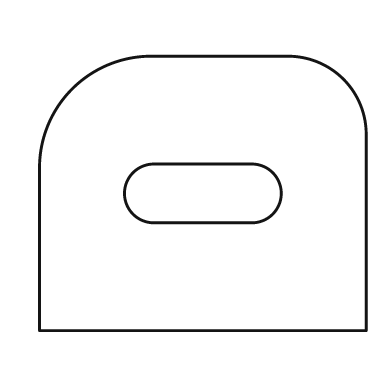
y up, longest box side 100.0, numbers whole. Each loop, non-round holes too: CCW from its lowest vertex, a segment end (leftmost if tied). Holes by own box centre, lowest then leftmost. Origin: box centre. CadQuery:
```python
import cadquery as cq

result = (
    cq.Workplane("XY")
    .moveTo(-50.0, -42.0)
    .lineTo(50.0, -42.0)
    .lineTo(50.0, 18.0)
    .threePointArc((43.0, 35.0), (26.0, 42.0))
    .lineTo(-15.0, 42.0)
    .threePointArc((-40.0, 32.0), (-50.0, 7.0))
    .close()
    .moveTo(-15.0, -9.0)
    .lineTo(15.0, -9.0)
    .threePointArc((24.0, 0.0), (15.0, 9.0))
    .lineTo(-15.0, 9.0)
    .threePointArc((-24.0, 0.0), (-15.0, -9.0))
    .close()
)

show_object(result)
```